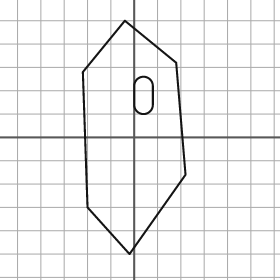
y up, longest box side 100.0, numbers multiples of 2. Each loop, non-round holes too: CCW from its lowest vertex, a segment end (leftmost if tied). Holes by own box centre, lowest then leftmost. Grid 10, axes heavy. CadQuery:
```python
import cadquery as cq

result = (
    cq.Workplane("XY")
    .moveTo(-2.0, -50.0)
    .lineTo(22.0, -16.0)
    .lineTo(18.0, 32.0)
    .lineTo(-4.0, 50.0)
    .lineTo(-22.0, 28.0)
    .lineTo(-20.0, -30.0)
    .close()
    .moveTo(0.0, 14.0)
    .threePointArc((4.0, 10.0), (8.0, 14.0))
    .lineTo(8.0, 22.0)
    .threePointArc((4.0, 26.0), (0.0, 22.0))
    .close()
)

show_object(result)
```